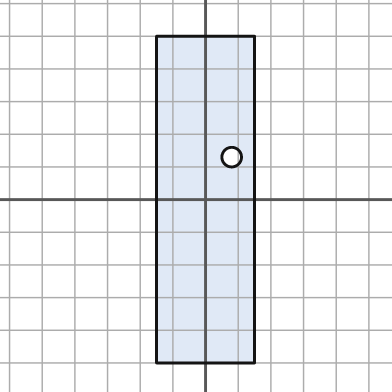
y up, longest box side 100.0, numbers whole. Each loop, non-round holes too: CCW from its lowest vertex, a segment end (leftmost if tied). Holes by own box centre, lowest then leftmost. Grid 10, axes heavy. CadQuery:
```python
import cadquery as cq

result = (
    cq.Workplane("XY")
    .moveTo(-15.0, -50.0)
    .lineTo(15.0, -50.0)
    .lineTo(15.0, 50.0)
    .lineTo(-15.0, 50.0)
    .close()
    .moveTo(8.0, 13.0)
    .circle(3.0)
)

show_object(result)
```